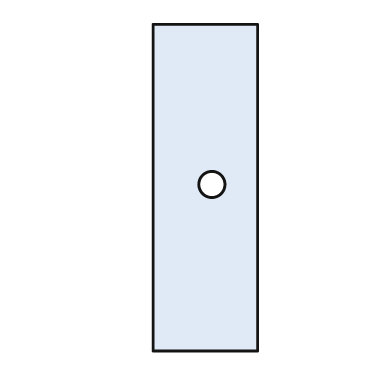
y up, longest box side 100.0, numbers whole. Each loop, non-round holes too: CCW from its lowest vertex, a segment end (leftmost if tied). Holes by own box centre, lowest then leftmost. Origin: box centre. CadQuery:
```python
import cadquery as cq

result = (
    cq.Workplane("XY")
    .moveTo(-16.0, -50.0)
    .lineTo(16.0, -50.0)
    .lineTo(16.0, 50.0)
    .lineTo(-16.0, 50.0)
    .close()
    .moveTo(2.0, 1.0)
    .circle(4.0)
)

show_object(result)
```